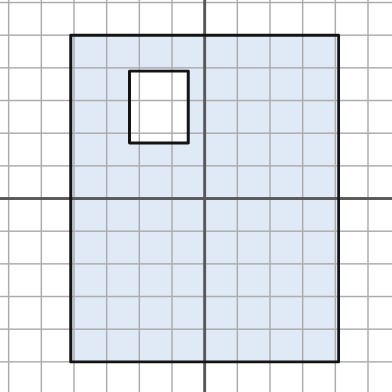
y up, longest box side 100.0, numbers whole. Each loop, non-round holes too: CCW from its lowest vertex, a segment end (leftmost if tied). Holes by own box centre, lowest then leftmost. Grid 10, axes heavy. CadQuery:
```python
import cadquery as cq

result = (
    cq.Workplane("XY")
    .moveTo(-41.0, -50.0)
    .lineTo(41.0, -50.0)
    .lineTo(41.0, 50.0)
    .lineTo(-41.0, 50.0)
    .close()
    .moveTo(-23.0, 17.0)
    .lineTo(-5.0, 17.0)
    .lineTo(-5.0, 39.0)
    .lineTo(-23.0, 39.0)
    .close()
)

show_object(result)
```